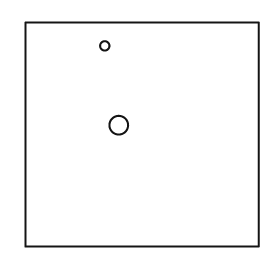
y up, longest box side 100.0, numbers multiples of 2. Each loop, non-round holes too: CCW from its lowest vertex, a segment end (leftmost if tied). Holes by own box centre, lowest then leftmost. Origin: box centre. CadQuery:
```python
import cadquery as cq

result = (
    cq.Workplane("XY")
    .moveTo(-50.0, -48.0)
    .lineTo(50.0, -48.0)
    .lineTo(50.0, 48.0)
    .lineTo(-50.0, 48.0)
    .close()
    .moveTo(-10.0, 4.0)
    .circle(4.0)
    .moveTo(-16.0, 38.0)
    .circle(2.0)
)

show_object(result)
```